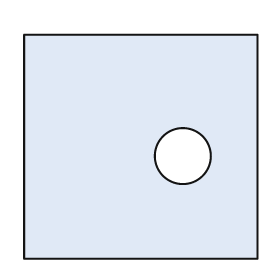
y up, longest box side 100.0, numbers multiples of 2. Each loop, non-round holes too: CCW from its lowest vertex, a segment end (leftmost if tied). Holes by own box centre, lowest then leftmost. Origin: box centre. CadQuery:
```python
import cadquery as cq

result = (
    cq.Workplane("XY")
    .moveTo(-50.0, -48.0)
    .lineTo(50.0, -48.0)
    .lineTo(50.0, 48.0)
    .lineTo(-50.0, 48.0)
    .close()
    .moveTo(18.0, -4.0)
    .circle(12.0)
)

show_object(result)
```